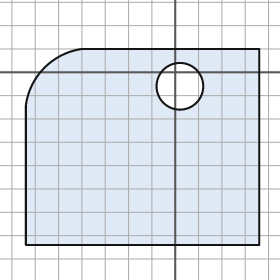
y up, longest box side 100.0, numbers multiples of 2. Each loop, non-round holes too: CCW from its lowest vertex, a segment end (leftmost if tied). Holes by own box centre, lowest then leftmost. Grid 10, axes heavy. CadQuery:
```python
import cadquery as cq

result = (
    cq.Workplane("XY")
    .moveTo(-64.0, -74.0)
    .lineTo(36.0, -74.0)
    .lineTo(36.0, 10.0)
    .lineTo(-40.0, 10.0)
    .threePointArc((-56.0, 2.0), (-64.0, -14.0))
    .close()
    .moveTo(2.0, -6.0)
    .circle(10.0)
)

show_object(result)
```